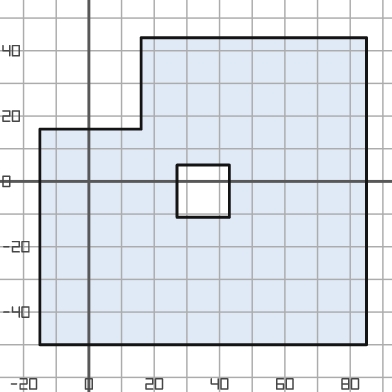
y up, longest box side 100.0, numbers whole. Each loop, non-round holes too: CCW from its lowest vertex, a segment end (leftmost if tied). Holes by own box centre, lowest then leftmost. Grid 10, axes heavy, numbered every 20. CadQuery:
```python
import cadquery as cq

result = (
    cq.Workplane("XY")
    .moveTo(-15.0, -50.0)
    .lineTo(85.0, -50.0)
    .lineTo(85.0, 44.0)
    .lineTo(16.0, 44.0)
    .lineTo(16.0, 16.0)
    .lineTo(-15.0, 16.0)
    .close()
    .moveTo(27.0, -11.0)
    .lineTo(43.0, -11.0)
    .lineTo(43.0, 5.0)
    .lineTo(27.0, 5.0)
    .close()
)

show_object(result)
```